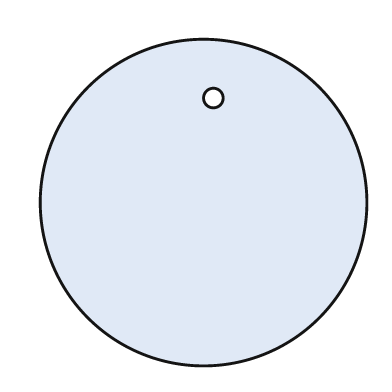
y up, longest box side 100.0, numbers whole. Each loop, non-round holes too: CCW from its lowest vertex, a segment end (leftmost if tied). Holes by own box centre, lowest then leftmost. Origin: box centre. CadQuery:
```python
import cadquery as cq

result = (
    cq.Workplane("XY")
    .moveTo(0.0, 0.0)
    .circle(50.0)
    .moveTo(3.0, 32.0)
    .circle(3.0)
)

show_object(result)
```